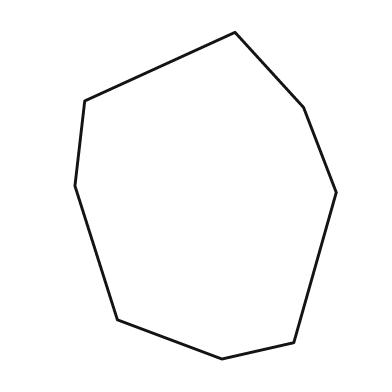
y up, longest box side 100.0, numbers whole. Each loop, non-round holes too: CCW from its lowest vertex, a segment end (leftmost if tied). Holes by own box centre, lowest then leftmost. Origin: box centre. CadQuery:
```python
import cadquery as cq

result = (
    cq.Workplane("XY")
    .moveTo(5.0, -50.0)
    .lineTo(27.0, -45.0)
    .lineTo(40.0, 1.0)
    .lineTo(30.0, 27.0)
    .lineTo(9.0, 50.0)
    .lineTo(-37.0, 29.0)
    .lineTo(-40.0, 3.0)
    .lineTo(-27.0, -38.0)
    .close()
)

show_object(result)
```